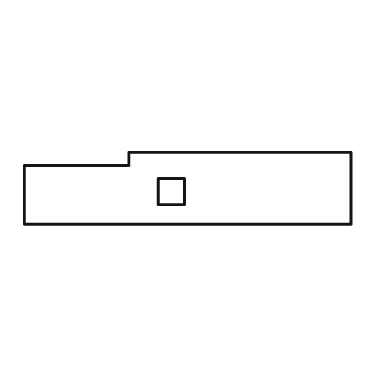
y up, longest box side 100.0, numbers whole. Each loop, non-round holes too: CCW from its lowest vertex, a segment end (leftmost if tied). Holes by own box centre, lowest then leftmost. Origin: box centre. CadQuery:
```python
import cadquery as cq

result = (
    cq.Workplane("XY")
    .moveTo(-50.0, -11.0)
    .lineTo(50.0, -11.0)
    .lineTo(50.0, 11.0)
    .lineTo(-18.0, 11.0)
    .lineTo(-18.0, 7.0)
    .lineTo(-50.0, 7.0)
    .close()
    .moveTo(-9.0, -5.0)
    .lineTo(-1.0, -5.0)
    .lineTo(-1.0, 3.0)
    .lineTo(-9.0, 3.0)
    .close()
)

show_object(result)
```